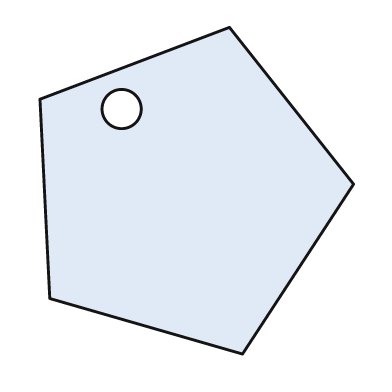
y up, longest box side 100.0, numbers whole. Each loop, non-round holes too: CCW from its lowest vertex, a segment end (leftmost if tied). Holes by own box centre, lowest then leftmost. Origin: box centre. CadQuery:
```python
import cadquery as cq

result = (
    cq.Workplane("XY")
    .moveTo(14.0, -50.0)
    .lineTo(48.0, 2.0)
    .lineTo(10.0, 50.0)
    .lineTo(-48.0, 28.0)
    .lineTo(-45.0, -33.0)
    .close()
    .moveTo(-23.0, 25.0)
    .circle(6.0)
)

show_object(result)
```